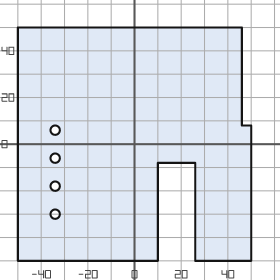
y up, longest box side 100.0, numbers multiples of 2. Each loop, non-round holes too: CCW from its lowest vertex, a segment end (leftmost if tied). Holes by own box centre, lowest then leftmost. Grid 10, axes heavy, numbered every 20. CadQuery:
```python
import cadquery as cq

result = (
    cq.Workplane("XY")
    .moveTo(-50.0, -50.0)
    .lineTo(10.0, -50.0)
    .lineTo(10.0, -8.0)
    .lineTo(26.0, -8.0)
    .lineTo(26.0, -50.0)
    .lineTo(50.0, -50.0)
    .lineTo(50.0, 8.0)
    .lineTo(46.0, 8.0)
    .lineTo(46.0, 50.0)
    .lineTo(-50.0, 50.0)
    .close()
    .moveTo(-34.0, -30.0)
    .circle(2.0)
    .moveTo(-34.0, -18.0)
    .circle(2.0)
    .moveTo(-34.0, -6.0)
    .circle(2.0)
    .moveTo(-34.0, 6.0)
    .circle(2.0)
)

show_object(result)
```